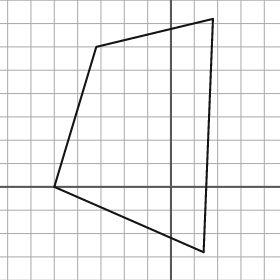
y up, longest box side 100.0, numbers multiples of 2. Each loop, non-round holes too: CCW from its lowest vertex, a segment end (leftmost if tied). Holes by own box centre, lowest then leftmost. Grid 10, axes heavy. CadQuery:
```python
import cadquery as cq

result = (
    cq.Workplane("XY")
    .moveTo(14.0, -28.0)
    .lineTo(18.0, 72.0)
    .lineTo(-32.0, 60.0)
    .lineTo(-50.0, 0.0)
    .close()
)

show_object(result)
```